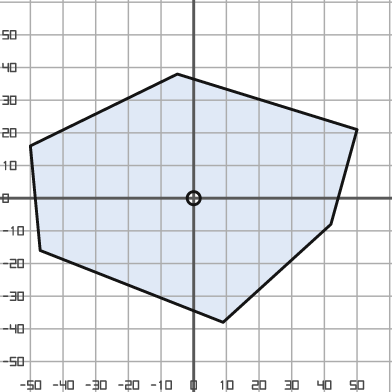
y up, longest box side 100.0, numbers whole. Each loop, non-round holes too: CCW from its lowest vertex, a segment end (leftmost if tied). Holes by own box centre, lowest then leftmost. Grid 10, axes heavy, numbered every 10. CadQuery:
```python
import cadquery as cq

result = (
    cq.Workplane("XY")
    .moveTo(9.0, -38.0)
    .lineTo(42.0, -8.0)
    .lineTo(50.0, 21.0)
    .lineTo(-5.0, 38.0)
    .lineTo(-50.0, 16.0)
    .lineTo(-47.0, -16.0)
    .close()
    .moveTo(0.0, 0.0)
    .circle(2.0)
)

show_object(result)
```